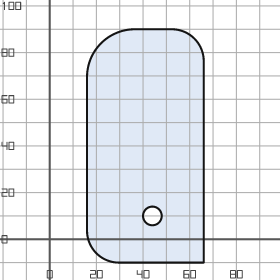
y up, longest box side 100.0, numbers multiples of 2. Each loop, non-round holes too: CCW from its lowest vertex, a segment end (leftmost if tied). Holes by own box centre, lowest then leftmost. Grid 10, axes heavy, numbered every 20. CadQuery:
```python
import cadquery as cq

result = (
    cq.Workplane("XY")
    .moveTo(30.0, -10.0)
    .lineTo(66.0, -10.0)
    .lineTo(66.0, 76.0)
    .threePointArc((62.0, 86.0), (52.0, 90.0))
    .lineTo(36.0, 90.0)
    .threePointArc((22.0, 84.0), (16.0, 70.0))
    .lineTo(16.0, 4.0)
    .threePointArc((20.0, -6.0), (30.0, -10.0))
    .close()
    .moveTo(44.0, 10.0)
    .circle(4.0)
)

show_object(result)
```